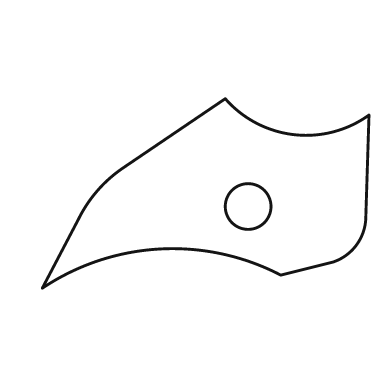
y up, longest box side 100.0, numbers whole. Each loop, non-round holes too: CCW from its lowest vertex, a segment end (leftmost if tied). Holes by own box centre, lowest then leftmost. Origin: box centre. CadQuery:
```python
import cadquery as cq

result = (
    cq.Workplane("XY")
    .moveTo(-50.0, -29.0)
    .threePointArc((-14.0, -17.0), (23.0, -25.0))
    .lineTo(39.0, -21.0)
    .threePointArc((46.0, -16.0), (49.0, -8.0))
    .lineTo(50.0, 24.0)
    .threePointArc((27.0, 18.0), (6.0, 29.0))
    .lineTo(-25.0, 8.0)
    .threePointArc((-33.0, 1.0), (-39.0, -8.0))
    .close()
    .moveTo(13.0, -4.0)
    .circle(7.0)
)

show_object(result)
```